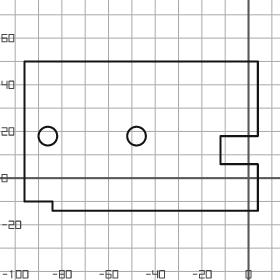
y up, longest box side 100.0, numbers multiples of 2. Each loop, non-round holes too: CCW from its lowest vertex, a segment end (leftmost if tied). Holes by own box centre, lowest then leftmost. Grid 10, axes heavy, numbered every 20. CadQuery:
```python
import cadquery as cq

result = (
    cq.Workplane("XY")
    .moveTo(-84.0, -14.0)
    .lineTo(4.0, -14.0)
    .lineTo(4.0, 6.0)
    .lineTo(-12.0, 6.0)
    .lineTo(-12.0, 18.0)
    .lineTo(4.0, 18.0)
    .lineTo(4.0, 50.0)
    .lineTo(-96.0, 50.0)
    .lineTo(-96.0, -10.0)
    .lineTo(-84.0, -10.0)
    .close()
    .moveTo(-86.0, 18.0)
    .circle(4.0)
    .moveTo(-48.0, 18.0)
    .circle(4.0)
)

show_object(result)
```